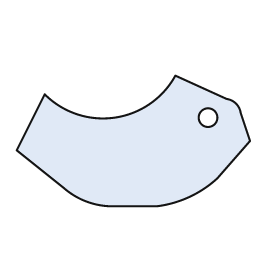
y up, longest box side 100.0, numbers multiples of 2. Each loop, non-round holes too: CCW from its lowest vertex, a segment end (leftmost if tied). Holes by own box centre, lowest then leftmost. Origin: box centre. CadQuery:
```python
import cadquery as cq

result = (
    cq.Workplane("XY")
    .moveTo(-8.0, -28.0)
    .lineTo(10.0, -28.0)
    .threePointArc((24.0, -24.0), (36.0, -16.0))
    .lineTo(50.0, 0.0)
    .lineTo(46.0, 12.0)
    .threePointArc((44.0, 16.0), (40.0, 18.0))
    .lineTo(18.0, 28.0)
    .threePointArc((-8.0, 10.0), (-38.0, 20.0))
    .lineTo(-50.0, -4.0)
    .lineTo(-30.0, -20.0)
    .threePointArc((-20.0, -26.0), (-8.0, -28.0))
    .close()
    .moveTo(32.0, 10.0)
    .circle(4.0)
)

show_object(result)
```